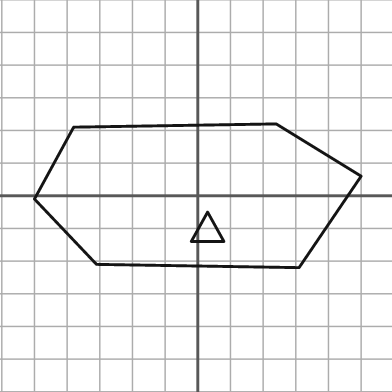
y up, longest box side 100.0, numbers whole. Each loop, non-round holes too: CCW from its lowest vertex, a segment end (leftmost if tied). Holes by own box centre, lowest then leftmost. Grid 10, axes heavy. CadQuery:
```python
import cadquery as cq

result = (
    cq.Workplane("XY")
    .moveTo(31.0, -22.0)
    .lineTo(50.0, 6.0)
    .lineTo(24.0, 22.0)
    .lineTo(-38.0, 21.0)
    .lineTo(-50.0, -1.0)
    .lineTo(-31.0, -21.0)
    .close()
    .moveTo(-2.0, -14.0)
    .lineTo(8.0, -14.0)
    .lineTo(3.0, -5.0)
    .close()
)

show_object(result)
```